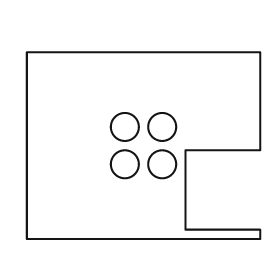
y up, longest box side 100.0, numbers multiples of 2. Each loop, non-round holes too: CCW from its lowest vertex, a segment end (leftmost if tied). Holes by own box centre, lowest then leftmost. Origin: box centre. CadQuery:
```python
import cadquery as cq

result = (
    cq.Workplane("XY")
    .moveTo(-50.0, -40.0)
    .lineTo(50.0, -40.0)
    .lineTo(50.0, -36.0)
    .lineTo(18.0, -36.0)
    .lineTo(18.0, -2.0)
    .lineTo(50.0, -2.0)
    .lineTo(50.0, 40.0)
    .lineTo(-50.0, 40.0)
    .close()
    .moveTo(-8.0, -8.0)
    .circle(6.0)
    .moveTo(8.0, -8.0)
    .circle(6.0)
    .moveTo(-8.0, 8.0)
    .circle(6.0)
    .moveTo(8.0, 8.0)
    .circle(6.0)
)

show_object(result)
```